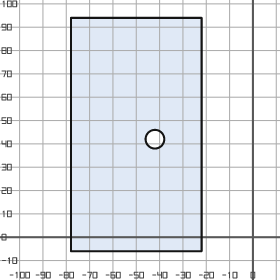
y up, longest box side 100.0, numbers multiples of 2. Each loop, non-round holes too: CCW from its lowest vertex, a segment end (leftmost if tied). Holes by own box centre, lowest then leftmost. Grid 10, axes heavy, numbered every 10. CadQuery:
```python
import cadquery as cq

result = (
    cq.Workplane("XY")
    .moveTo(-78.0, -6.0)
    .lineTo(-22.0, -6.0)
    .lineTo(-22.0, 94.0)
    .lineTo(-78.0, 94.0)
    .close()
    .moveTo(-42.0, 42.0)
    .circle(4.0)
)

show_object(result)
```